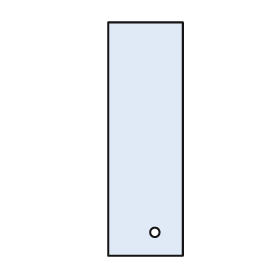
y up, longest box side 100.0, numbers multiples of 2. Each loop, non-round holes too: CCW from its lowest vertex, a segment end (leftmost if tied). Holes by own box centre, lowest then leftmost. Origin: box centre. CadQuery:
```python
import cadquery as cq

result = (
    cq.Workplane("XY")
    .moveTo(-16.0, -50.0)
    .lineTo(16.0, -50.0)
    .lineTo(16.0, 50.0)
    .lineTo(-16.0, 50.0)
    .close()
    .moveTo(4.0, -40.0)
    .circle(2.0)
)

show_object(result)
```